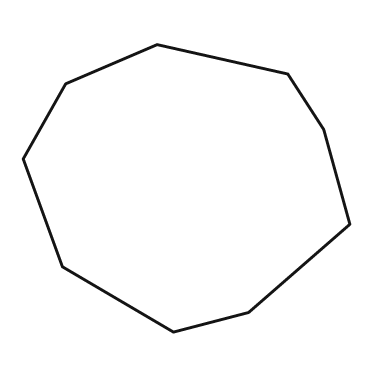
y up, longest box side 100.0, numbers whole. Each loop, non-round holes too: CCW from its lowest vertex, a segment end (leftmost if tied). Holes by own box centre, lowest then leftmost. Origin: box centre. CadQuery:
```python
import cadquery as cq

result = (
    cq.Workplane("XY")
    .moveTo(-4.0, -44.0)
    .lineTo(19.0, -38.0)
    .lineTo(50.0, -11.0)
    .lineTo(42.0, 18.0)
    .lineTo(31.0, 35.0)
    .lineTo(-9.0, 44.0)
    .lineTo(-37.0, 32.0)
    .lineTo(-50.0, 9.0)
    .lineTo(-38.0, -24.0)
    .close()
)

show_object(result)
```